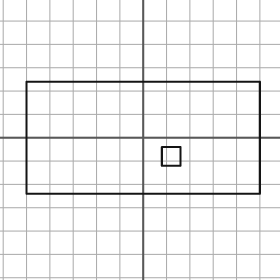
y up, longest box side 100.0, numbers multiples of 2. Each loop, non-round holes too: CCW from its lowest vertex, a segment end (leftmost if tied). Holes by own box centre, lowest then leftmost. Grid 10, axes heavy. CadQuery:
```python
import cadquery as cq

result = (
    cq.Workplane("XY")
    .moveTo(-50.0, -24.0)
    .lineTo(50.0, -24.0)
    .lineTo(50.0, 24.0)
    .lineTo(-50.0, 24.0)
    .close()
    .moveTo(8.0, -12.0)
    .lineTo(16.0, -12.0)
    .lineTo(16.0, -4.0)
    .lineTo(8.0, -4.0)
    .close()
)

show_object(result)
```